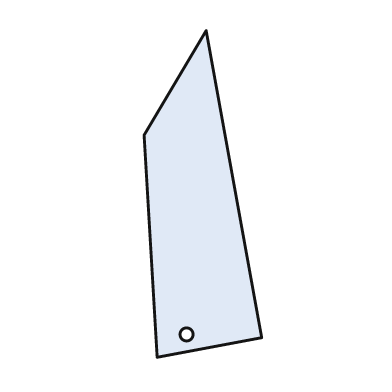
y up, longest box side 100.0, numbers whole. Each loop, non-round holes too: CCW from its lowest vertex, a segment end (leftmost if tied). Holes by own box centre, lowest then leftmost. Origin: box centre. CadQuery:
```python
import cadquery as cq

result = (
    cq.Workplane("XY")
    .moveTo(-14.0, -50.0)
    .lineTo(18.0, -44.0)
    .lineTo(1.0, 50.0)
    .lineTo(-18.0, 18.0)
    .close()
    .moveTo(-5.0, -43.0)
    .circle(2.0)
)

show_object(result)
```